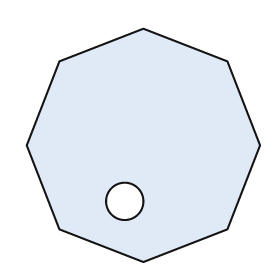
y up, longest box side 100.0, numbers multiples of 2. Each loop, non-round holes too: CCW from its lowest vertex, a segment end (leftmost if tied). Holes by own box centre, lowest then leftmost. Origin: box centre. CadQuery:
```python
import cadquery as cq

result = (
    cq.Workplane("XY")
    .moveTo(0.0, -50.0)
    .lineTo(36.0, -36.0)
    .lineTo(50.0, 0.0)
    .lineTo(36.0, 36.0)
    .lineTo(0.0, 50.0)
    .lineTo(-36.0, 36.0)
    .lineTo(-50.0, 0.0)
    .lineTo(-36.0, -36.0)
    .close()
    .moveTo(-8.0, -24.0)
    .circle(8.0)
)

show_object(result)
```